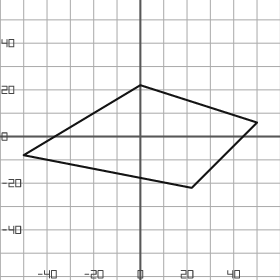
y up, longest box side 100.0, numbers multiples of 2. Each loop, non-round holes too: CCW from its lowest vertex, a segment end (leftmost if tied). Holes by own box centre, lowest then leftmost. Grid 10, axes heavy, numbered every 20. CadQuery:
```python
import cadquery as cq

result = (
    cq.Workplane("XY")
    .moveTo(22.0, -22.0)
    .lineTo(50.0, 6.0)
    .lineTo(0.0, 22.0)
    .lineTo(-50.0, -8.0)
    .close()
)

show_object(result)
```